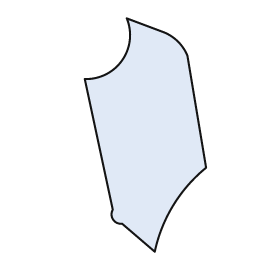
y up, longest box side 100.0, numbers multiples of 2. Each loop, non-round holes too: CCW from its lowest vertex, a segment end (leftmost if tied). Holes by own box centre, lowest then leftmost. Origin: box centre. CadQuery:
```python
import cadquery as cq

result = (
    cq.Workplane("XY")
    .moveTo(4.0, -50.0)
    .threePointArc((12.0, -30.0), (26.0, -14.0))
    .lineTo(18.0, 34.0)
    .threePointArc((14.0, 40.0), (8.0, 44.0))
    .lineTo(-8.0, 50.0)
    .threePointArc((-10.0, 32.0), (-26.0, 24.0))
    .lineTo(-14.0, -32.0)
    .threePointArc((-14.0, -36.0), (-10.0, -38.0))
    .close()
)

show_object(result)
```